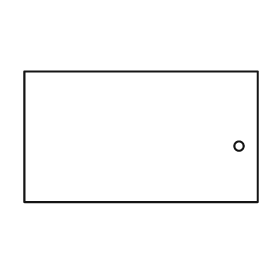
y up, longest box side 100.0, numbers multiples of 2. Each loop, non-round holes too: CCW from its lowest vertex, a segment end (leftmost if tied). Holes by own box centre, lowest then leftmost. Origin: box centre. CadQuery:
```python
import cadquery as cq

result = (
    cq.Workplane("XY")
    .moveTo(-50.0, -28.0)
    .lineTo(50.0, -28.0)
    .lineTo(50.0, 28.0)
    .lineTo(-50.0, 28.0)
    .close()
    .moveTo(42.0, -4.0)
    .circle(2.0)
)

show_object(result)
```